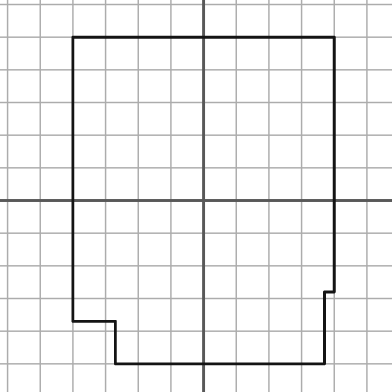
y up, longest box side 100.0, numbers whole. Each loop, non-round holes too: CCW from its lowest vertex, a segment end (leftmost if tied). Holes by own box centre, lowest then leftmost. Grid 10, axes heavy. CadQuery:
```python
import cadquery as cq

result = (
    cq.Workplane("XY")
    .moveTo(-27.0, -50.0)
    .lineTo(37.0, -50.0)
    .lineTo(37.0, -28.0)
    .lineTo(40.0, -28.0)
    .lineTo(40.0, 50.0)
    .lineTo(-40.0, 50.0)
    .lineTo(-40.0, -37.0)
    .lineTo(-27.0, -37.0)
    .close()
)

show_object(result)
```